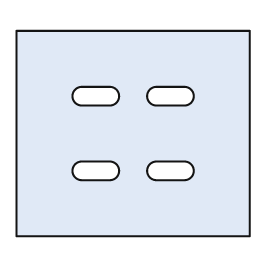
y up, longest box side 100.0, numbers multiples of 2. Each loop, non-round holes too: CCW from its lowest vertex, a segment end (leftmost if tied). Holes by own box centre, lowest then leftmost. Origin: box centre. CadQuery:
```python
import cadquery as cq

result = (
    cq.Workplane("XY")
    .moveTo(-50.0, -44.0)
    .lineTo(50.0, -44.0)
    .lineTo(50.0, 44.0)
    .lineTo(-50.0, 44.0)
    .close()
    .moveTo(-22.0, -20.0)
    .lineTo(-10.0, -20.0)
    .threePointArc((-6.0, -16.0), (-10.0, -12.0))
    .lineTo(-22.0, -12.0)
    .threePointArc((-26.0, -16.0), (-22.0, -20.0))
    .close()
    .moveTo(10.0, -20.0)
    .lineTo(22.0, -20.0)
    .threePointArc((26.0, -16.0), (22.0, -12.0))
    .lineTo(10.0, -12.0)
    .threePointArc((6.0, -16.0), (10.0, -20.0))
    .close()
    .moveTo(-22.0, 12.0)
    .lineTo(-10.0, 12.0)
    .threePointArc((-6.0, 16.0), (-10.0, 20.0))
    .lineTo(-22.0, 20.0)
    .threePointArc((-26.0, 16.0), (-22.0, 12.0))
    .close()
    .moveTo(10.0, 12.0)
    .lineTo(22.0, 12.0)
    .threePointArc((26.0, 16.0), (22.0, 20.0))
    .lineTo(10.0, 20.0)
    .threePointArc((6.0, 16.0), (10.0, 12.0))
    .close()
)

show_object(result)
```